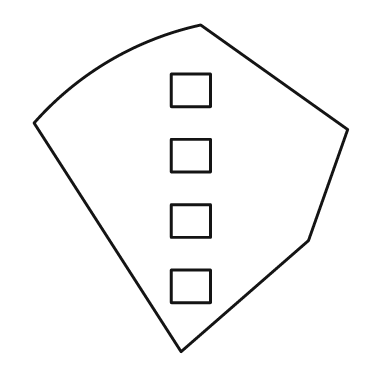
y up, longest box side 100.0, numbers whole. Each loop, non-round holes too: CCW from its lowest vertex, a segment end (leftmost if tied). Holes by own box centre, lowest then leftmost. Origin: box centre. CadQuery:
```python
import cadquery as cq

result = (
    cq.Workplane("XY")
    .moveTo(-3.0, -50.0)
    .lineTo(36.0, -16.0)
    .lineTo(48.0, 18.0)
    .lineTo(3.0, 50.0)
    .threePointArc((-25.0, 39.0), (-48.0, 20.0))
    .close()
    .moveTo(-6.0, -35.0)
    .lineTo(6.0, -35.0)
    .lineTo(6.0, -25.0)
    .lineTo(-6.0, -25.0)
    .close()
    .moveTo(-6.0, -15.0)
    .lineTo(6.0, -15.0)
    .lineTo(6.0, -5.0)
    .lineTo(-6.0, -5.0)
    .close()
    .moveTo(-6.0, 5.0)
    .lineTo(6.0, 5.0)
    .lineTo(6.0, 15.0)
    .lineTo(-6.0, 15.0)
    .close()
    .moveTo(-6.0, 25.0)
    .lineTo(6.0, 25.0)
    .lineTo(6.0, 35.0)
    .lineTo(-6.0, 35.0)
    .close()
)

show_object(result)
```